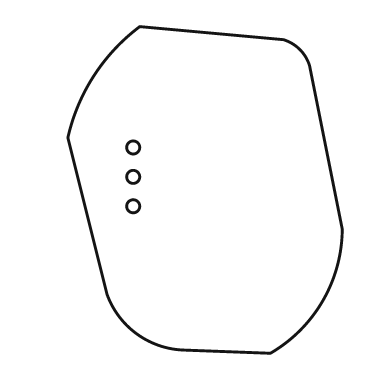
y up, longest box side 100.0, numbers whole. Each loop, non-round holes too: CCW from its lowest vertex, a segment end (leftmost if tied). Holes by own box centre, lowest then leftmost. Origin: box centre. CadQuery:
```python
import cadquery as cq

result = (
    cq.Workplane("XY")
    .moveTo(20.0, -50.0)
    .threePointArc((36.0, -34.0), (42.0, -12.0))
    .lineTo(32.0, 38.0)
    .threePointArc((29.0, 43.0), (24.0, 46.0))
    .lineTo(-20.0, 50.0)
    .threePointArc((-34.0, 35.0), (-42.0, 16.0))
    .lineTo(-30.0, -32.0)
    .threePointArc((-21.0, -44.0), (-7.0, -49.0))
    .close()
    .moveTo(-22.0, -5.0)
    .circle(2.0)
    .moveTo(-22.0, 4.0)
    .circle(2.0)
    .moveTo(-22.0, 13.0)
    .circle(2.0)
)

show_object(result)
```